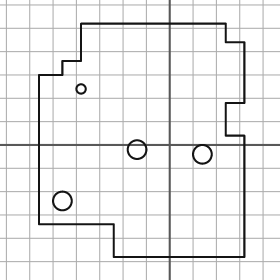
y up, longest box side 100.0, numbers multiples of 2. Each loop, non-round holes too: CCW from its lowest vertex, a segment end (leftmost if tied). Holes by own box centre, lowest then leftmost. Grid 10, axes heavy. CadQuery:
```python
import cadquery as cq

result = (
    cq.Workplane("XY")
    .moveTo(-24.0, -48.0)
    .lineTo(32.0, -48.0)
    .lineTo(32.0, 4.0)
    .lineTo(24.0, 4.0)
    .lineTo(24.0, 18.0)
    .lineTo(32.0, 18.0)
    .lineTo(32.0, 44.0)
    .lineTo(24.0, 44.0)
    .lineTo(24.0, 52.0)
    .lineTo(-38.0, 52.0)
    .lineTo(-38.0, 36.0)
    .lineTo(-46.0, 36.0)
    .lineTo(-46.0, 30.0)
    .lineTo(-56.0, 30.0)
    .lineTo(-56.0, -34.0)
    .lineTo(-24.0, -34.0)
    .close()
    .moveTo(-46.0, -24.0)
    .circle(4.0)
    .moveTo(14.0, -4.0)
    .circle(4.0)
    .moveTo(-14.0, -2.0)
    .circle(4.0)
    .moveTo(-38.0, 24.0)
    .circle(2.0)
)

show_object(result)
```